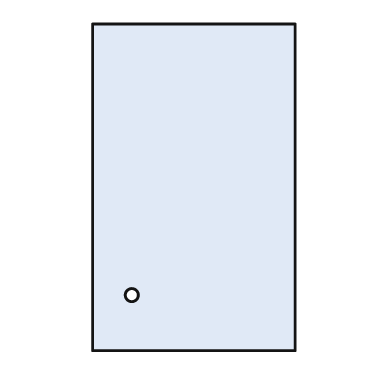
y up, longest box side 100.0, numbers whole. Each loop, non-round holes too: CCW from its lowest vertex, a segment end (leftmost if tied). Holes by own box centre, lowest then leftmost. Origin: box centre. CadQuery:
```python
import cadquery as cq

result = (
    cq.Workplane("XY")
    .moveTo(-31.0, -50.0)
    .lineTo(31.0, -50.0)
    .lineTo(31.0, 50.0)
    .lineTo(-31.0, 50.0)
    .close()
    .moveTo(-19.0, -33.0)
    .circle(2.0)
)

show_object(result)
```